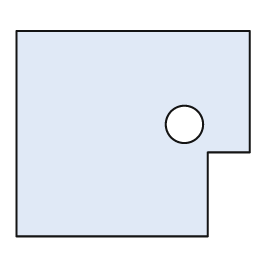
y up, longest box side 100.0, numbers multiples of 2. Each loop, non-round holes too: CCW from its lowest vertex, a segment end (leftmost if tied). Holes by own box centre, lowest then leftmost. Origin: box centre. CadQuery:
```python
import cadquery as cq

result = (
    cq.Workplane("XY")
    .moveTo(-50.0, -44.0)
    .lineTo(32.0, -44.0)
    .lineTo(32.0, -8.0)
    .lineTo(50.0, -8.0)
    .lineTo(50.0, 44.0)
    .lineTo(-50.0, 44.0)
    .close()
    .moveTo(22.0, 4.0)
    .circle(8.0)
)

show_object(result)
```